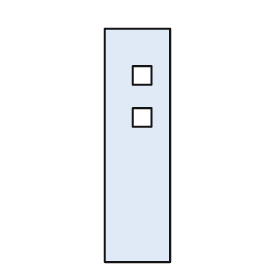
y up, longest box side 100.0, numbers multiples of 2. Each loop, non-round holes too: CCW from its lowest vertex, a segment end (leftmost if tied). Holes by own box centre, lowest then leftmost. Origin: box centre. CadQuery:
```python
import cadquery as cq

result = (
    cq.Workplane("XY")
    .moveTo(-14.0, -50.0)
    .lineTo(14.0, -50.0)
    .lineTo(14.0, 50.0)
    .lineTo(-14.0, 50.0)
    .close()
    .moveTo(-2.0, 8.0)
    .lineTo(6.0, 8.0)
    .lineTo(6.0, 16.0)
    .lineTo(-2.0, 16.0)
    .close()
    .moveTo(-2.0, 26.0)
    .lineTo(6.0, 26.0)
    .lineTo(6.0, 34.0)
    .lineTo(-2.0, 34.0)
    .close()
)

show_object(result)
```